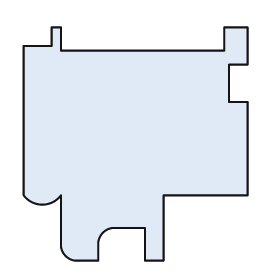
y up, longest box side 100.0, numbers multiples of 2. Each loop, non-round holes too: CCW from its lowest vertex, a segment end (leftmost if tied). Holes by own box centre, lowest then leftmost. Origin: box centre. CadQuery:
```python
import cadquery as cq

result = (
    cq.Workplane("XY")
    .moveTo(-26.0, -50.0)
    .lineTo(-16.0, -50.0)
    .lineTo(-16.0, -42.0)
    .threePointArc((-14.0, -38.0), (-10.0, -36.0))
    .lineTo(4.0, -36.0)
    .lineTo(4.0, -50.0)
    .lineTo(12.0, -50.0)
    .lineTo(12.0, -22.0)
    .lineTo(48.0, -22.0)
    .lineTo(48.0, 18.0)
    .lineTo(40.0, 18.0)
    .lineTo(40.0, 34.0)
    .lineTo(48.0, 34.0)
    .lineTo(48.0, 50.0)
    .lineTo(38.0, 50.0)
    .lineTo(38.0, 40.0)
    .lineTo(-32.0, 40.0)
    .lineTo(-32.0, 50.0)
    .lineTo(-36.0, 50.0)
    .lineTo(-36.0, 42.0)
    .lineTo(-48.0, 42.0)
    .lineTo(-48.0, -22.0)
    .threePointArc((-40.0, -26.0), (-32.0, -22.0))
    .lineTo(-32.0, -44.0)
    .threePointArc((-30.0, -48.0), (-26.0, -50.0))
    .close()
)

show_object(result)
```